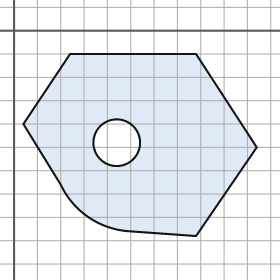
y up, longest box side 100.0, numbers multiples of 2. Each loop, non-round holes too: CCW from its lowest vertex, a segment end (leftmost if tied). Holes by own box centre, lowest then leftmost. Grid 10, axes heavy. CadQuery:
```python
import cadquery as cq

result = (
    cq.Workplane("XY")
    .moveTo(78.0, -88.0)
    .lineTo(104.0, -50.0)
    .lineTo(78.0, -10.0)
    .lineTo(24.0, -10.0)
    .lineTo(4.0, -40.0)
    .lineTo(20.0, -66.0)
    .threePointArc((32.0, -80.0), (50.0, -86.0))
    .close()
    .moveTo(44.0, -48.0)
    .circle(10.0)
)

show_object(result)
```